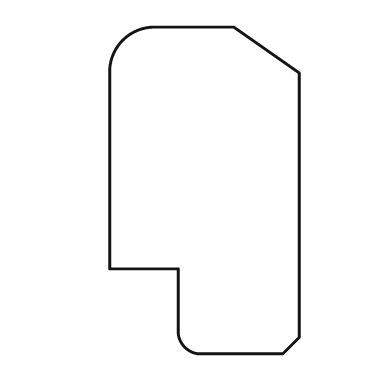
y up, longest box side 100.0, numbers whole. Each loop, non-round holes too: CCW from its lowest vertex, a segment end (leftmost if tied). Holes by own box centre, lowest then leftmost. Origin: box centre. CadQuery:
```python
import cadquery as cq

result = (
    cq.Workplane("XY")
    .moveTo(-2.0, -50.0)
    .lineTo(24.0, -50.0)
    .lineTo(29.0, -45.0)
    .lineTo(29.0, 36.0)
    .lineTo(9.0, 50.0)
    .lineTo(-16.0, 50.0)
    .threePointArc((-25.0, 46.0), (-29.0, 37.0))
    .lineTo(-29.0, -24.0)
    .lineTo(-8.0, -24.0)
    .lineTo(-8.0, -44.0)
    .threePointArc((-6.0, -48.0), (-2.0, -50.0))
    .close()
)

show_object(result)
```